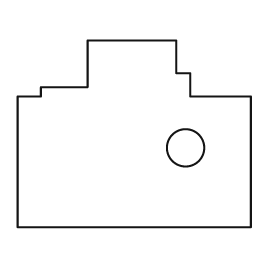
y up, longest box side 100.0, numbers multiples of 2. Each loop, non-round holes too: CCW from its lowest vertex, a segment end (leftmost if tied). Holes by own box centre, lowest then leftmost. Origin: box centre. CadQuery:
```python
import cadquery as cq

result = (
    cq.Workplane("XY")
    .moveTo(-50.0, -40.0)
    .lineTo(50.0, -40.0)
    .lineTo(50.0, 16.0)
    .lineTo(24.0, 16.0)
    .lineTo(24.0, 26.0)
    .lineTo(18.0, 26.0)
    .lineTo(18.0, 40.0)
    .lineTo(-20.0, 40.0)
    .lineTo(-20.0, 20.0)
    .lineTo(-40.0, 20.0)
    .lineTo(-40.0, 16.0)
    .lineTo(-50.0, 16.0)
    .close()
    .moveTo(22.0, -6.0)
    .circle(8.0)
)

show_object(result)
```